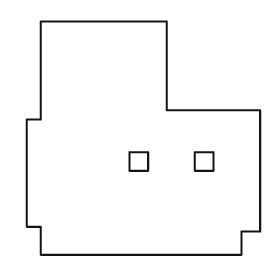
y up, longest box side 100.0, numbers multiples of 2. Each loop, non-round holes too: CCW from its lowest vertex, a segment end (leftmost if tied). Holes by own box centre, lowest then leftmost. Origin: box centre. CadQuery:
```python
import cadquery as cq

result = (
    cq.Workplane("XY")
    .moveTo(-44.0, -50.0)
    .lineTo(42.0, -50.0)
    .lineTo(42.0, -40.0)
    .lineTo(50.0, -40.0)
    .lineTo(50.0, 12.0)
    .lineTo(10.0, 12.0)
    .lineTo(10.0, 50.0)
    .lineTo(-44.0, 50.0)
    .lineTo(-44.0, 8.0)
    .lineTo(-50.0, 8.0)
    .lineTo(-50.0, -38.0)
    .lineTo(-44.0, -38.0)
    .close()
    .moveTo(-6.0, -14.0)
    .lineTo(2.0, -14.0)
    .lineTo(2.0, -6.0)
    .lineTo(-6.0, -6.0)
    .close()
    .moveTo(22.0, -14.0)
    .lineTo(30.0, -14.0)
    .lineTo(30.0, -6.0)
    .lineTo(22.0, -6.0)
    .close()
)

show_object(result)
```